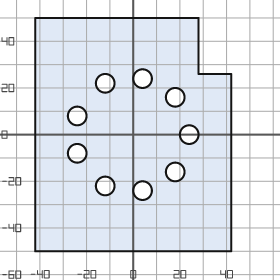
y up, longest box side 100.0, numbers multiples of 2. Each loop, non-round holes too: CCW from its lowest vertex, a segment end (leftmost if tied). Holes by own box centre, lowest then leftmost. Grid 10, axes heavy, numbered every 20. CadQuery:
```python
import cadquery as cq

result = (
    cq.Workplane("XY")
    .moveTo(-42.0, -50.0)
    .lineTo(42.0, -50.0)
    .lineTo(42.0, 26.0)
    .lineTo(28.0, 26.0)
    .lineTo(28.0, 50.0)
    .lineTo(-42.0, 50.0)
    .close()
    .moveTo(4.0, -24.0)
    .circle(4.0)
    .moveTo(-12.0, -22.0)
    .circle(4.0)
    .moveTo(18.0, -16.0)
    .circle(4.0)
    .moveTo(-24.0, -8.0)
    .circle(4.0)
    .moveTo(24.0, 0.0)
    .circle(4.0)
    .moveTo(-24.0, 8.0)
    .circle(4.0)
    .moveTo(18.0, 16.0)
    .circle(4.0)
    .moveTo(-12.0, 22.0)
    .circle(4.0)
    .moveTo(4.0, 24.0)
    .circle(4.0)
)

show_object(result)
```